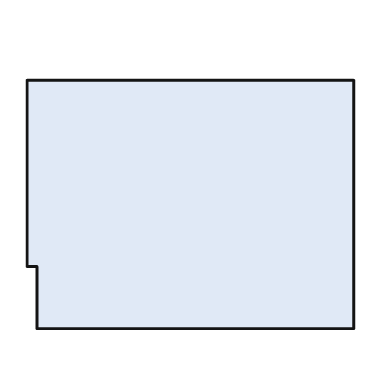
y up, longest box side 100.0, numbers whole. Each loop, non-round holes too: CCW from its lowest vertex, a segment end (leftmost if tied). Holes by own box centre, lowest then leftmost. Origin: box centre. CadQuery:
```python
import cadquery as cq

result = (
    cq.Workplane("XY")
    .moveTo(-47.0, -38.0)
    .lineTo(50.0, -38.0)
    .lineTo(50.0, 38.0)
    .lineTo(-50.0, 38.0)
    .lineTo(-50.0, -19.0)
    .lineTo(-47.0, -19.0)
    .close()
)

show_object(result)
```